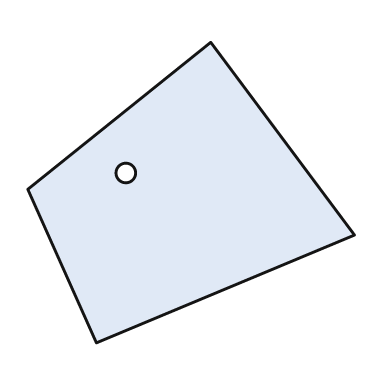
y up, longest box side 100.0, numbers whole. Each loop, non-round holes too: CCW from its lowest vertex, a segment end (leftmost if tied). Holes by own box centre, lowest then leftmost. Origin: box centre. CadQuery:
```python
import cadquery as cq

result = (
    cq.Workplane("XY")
    .moveTo(-29.0, -46.0)
    .lineTo(50.0, -13.0)
    .lineTo(6.0, 46.0)
    .lineTo(-50.0, 1.0)
    .close()
    .moveTo(-20.0, 6.0)
    .circle(3.0)
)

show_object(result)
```